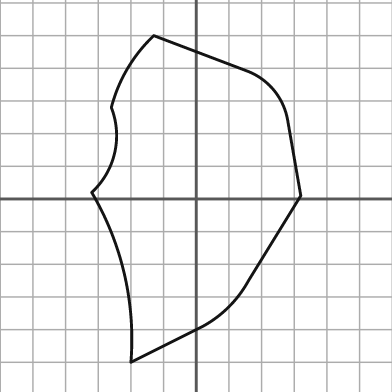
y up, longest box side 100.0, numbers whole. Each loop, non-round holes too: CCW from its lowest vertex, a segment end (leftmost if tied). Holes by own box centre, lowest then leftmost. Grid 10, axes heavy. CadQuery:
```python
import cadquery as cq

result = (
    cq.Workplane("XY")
    .moveTo(-20.0, -50.0)
    .lineTo(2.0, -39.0)
    .threePointArc((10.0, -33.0), (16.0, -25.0))
    .lineTo(32.0, 1.0)
    .lineTo(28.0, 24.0)
    .threePointArc((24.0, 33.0), (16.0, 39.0))
    .lineTo(-13.0, 50.0)
    .threePointArc((-21.0, 40.0), (-26.0, 28.0))
    .threePointArc((-25.0, 14.0), (-32.0, 2.0))
    .threePointArc((-22.0, -23.0), (-20.0, -50.0))
    .close()
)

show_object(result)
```